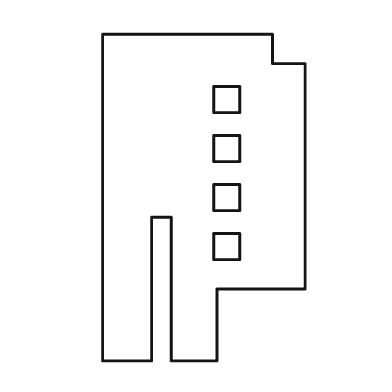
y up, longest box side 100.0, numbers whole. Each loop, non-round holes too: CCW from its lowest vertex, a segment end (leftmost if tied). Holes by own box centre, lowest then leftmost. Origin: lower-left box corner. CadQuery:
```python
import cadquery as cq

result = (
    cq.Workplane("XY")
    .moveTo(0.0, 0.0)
    .lineTo(15.0, 0.0)
    .lineTo(15.0, 44.0)
    .lineTo(21.0, 44.0)
    .lineTo(21.0, 0.0)
    .lineTo(35.0, 0.0)
    .lineTo(35.0, 22.0)
    .lineTo(62.0, 22.0)
    .lineTo(62.0, 91.0)
    .lineTo(52.0, 91.0)
    .lineTo(52.0, 100.0)
    .lineTo(0.0, 100.0)
    .close()
    .moveTo(34.0, 31.0)
    .lineTo(42.0, 31.0)
    .lineTo(42.0, 39.0)
    .lineTo(34.0, 39.0)
    .close()
    .moveTo(34.0, 46.0)
    .lineTo(42.0, 46.0)
    .lineTo(42.0, 54.0)
    .lineTo(34.0, 54.0)
    .close()
    .moveTo(34.0, 61.0)
    .lineTo(42.0, 61.0)
    .lineTo(42.0, 69.0)
    .lineTo(34.0, 69.0)
    .close()
    .moveTo(34.0, 76.0)
    .lineTo(42.0, 76.0)
    .lineTo(42.0, 84.0)
    .lineTo(34.0, 84.0)
    .close()
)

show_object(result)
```